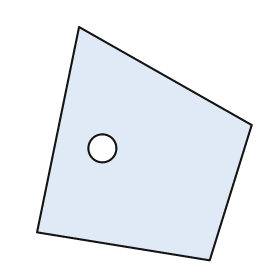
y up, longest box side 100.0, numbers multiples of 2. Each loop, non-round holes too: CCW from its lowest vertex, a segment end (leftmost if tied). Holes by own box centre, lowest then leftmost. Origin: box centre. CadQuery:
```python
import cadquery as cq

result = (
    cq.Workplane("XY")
    .moveTo(28.0, -50.0)
    .lineTo(46.0, 8.0)
    .lineTo(-28.0, 50.0)
    .lineTo(-46.0, -38.0)
    .close()
    .moveTo(-18.0, -2.0)
    .circle(6.0)
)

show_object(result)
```